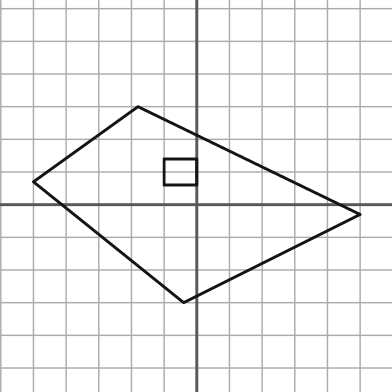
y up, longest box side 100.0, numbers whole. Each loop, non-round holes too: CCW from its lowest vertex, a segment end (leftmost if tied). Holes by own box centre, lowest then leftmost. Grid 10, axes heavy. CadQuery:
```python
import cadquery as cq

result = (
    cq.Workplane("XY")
    .moveTo(-4.0, -30.0)
    .lineTo(50.0, -3.0)
    .lineTo(-18.0, 30.0)
    .lineTo(-50.0, 7.0)
    .close()
    .moveTo(-10.0, 6.0)
    .lineTo(0.0, 6.0)
    .lineTo(0.0, 14.0)
    .lineTo(-10.0, 14.0)
    .close()
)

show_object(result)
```